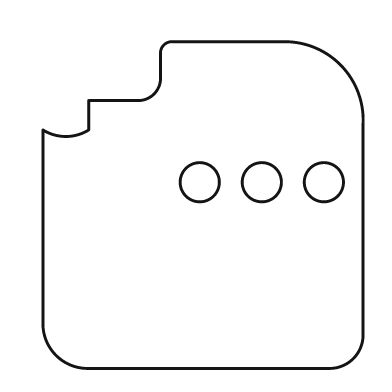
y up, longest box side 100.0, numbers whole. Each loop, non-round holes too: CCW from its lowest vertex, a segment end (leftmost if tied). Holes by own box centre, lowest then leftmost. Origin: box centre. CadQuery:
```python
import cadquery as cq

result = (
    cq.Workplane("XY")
    .moveTo(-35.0, -50.0)
    .lineTo(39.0, -50.0)
    .threePointArc((46.0, -47.0), (49.0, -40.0))
    .lineTo(49.0, 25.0)
    .threePointArc((42.0, 43.0), (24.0, 50.0))
    .lineTo(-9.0, 50.0)
    .threePointArc((-12.0, 49.0), (-13.0, 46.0))
    .lineTo(-13.0, 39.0)
    .threePointArc((-15.0, 34.0), (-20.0, 32.0))
    .lineTo(-35.0, 32.0)
    .lineTo(-35.0, 23.0)
    .threePointArc((-42.0, 21.0), (-49.0, 23.0))
    .lineTo(-49.0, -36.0)
    .threePointArc((-45.0, -46.0), (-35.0, -50.0))
    .close()
    .moveTo(-1.0, 7.0)
    .circle(6.0)
    .moveTo(18.0, 7.0)
    .circle(6.0)
    .moveTo(37.0, 7.0)
    .circle(6.0)
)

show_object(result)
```